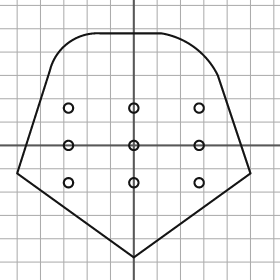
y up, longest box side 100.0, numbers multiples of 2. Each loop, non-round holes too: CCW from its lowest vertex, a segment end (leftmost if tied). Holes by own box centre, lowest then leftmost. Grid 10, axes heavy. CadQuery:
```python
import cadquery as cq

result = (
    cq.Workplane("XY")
    .moveTo(0.0, -48.0)
    .lineTo(50.0, -12.0)
    .lineTo(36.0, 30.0)
    .threePointArc((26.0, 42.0), (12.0, 48.0))
    .lineTo(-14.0, 48.0)
    .threePointArc((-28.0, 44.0), (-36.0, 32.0))
    .lineTo(-50.0, -12.0)
    .close()
    .moveTo(-28.0, -16.0)
    .circle(2.0)
    .moveTo(0.0, -16.0)
    .circle(2.0)
    .moveTo(28.0, -16.0)
    .circle(2.0)
    .moveTo(-28.0, 0.0)
    .circle(2.0)
    .moveTo(0.0, 0.0)
    .circle(2.0)
    .moveTo(28.0, 0.0)
    .circle(2.0)
    .moveTo(-28.0, 16.0)
    .circle(2.0)
    .moveTo(0.0, 16.0)
    .circle(2.0)
    .moveTo(28.0, 16.0)
    .circle(2.0)
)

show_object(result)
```